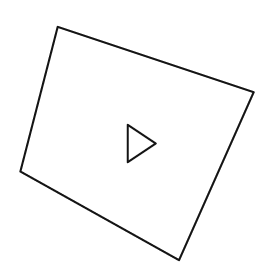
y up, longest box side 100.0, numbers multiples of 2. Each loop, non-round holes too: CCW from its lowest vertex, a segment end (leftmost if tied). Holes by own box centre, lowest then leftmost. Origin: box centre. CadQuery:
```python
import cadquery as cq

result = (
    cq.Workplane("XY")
    .moveTo(18.0, -50.0)
    .lineTo(50.0, 22.0)
    .lineTo(-34.0, 50.0)
    .lineTo(-50.0, -12.0)
    .close()
    .moveTo(-4.0, -8.0)
    .lineTo(8.0, 0.0)
    .lineTo(-4.0, 8.0)
    .close()
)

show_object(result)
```